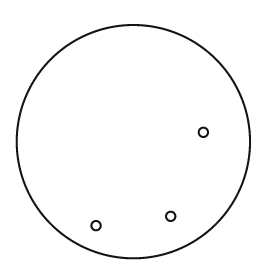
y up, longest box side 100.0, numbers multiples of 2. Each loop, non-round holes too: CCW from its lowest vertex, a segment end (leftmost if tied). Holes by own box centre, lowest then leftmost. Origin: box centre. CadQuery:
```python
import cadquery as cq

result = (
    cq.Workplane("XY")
    .moveTo(0.0, 0.0)
    .circle(50.0)
    .moveTo(-16.0, -36.0)
    .circle(2.0)
    .moveTo(16.0, -32.0)
    .circle(2.0)
    .moveTo(30.0, 4.0)
    .circle(2.0)
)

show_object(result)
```